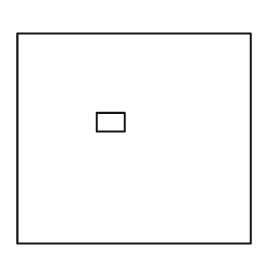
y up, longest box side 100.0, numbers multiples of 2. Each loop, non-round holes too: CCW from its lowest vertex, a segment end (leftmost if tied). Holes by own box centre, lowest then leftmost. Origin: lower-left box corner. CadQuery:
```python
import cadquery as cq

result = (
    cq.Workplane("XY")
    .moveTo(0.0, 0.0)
    .lineTo(100.0, 0.0)
    .lineTo(100.0, 90.0)
    .lineTo(0.0, 90.0)
    .close()
    .moveTo(34.0, 48.0)
    .lineTo(46.0, 48.0)
    .lineTo(46.0, 56.0)
    .lineTo(34.0, 56.0)
    .close()
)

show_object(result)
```